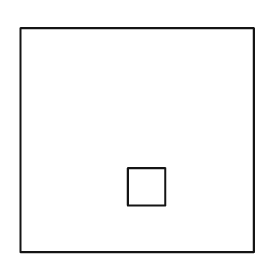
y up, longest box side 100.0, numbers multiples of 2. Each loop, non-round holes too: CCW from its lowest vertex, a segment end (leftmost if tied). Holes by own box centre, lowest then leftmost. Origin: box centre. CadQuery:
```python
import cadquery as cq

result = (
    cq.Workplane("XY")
    .moveTo(-50.0, -48.0)
    .lineTo(50.0, -48.0)
    .lineTo(50.0, 48.0)
    .lineTo(-50.0, 48.0)
    .close()
    .moveTo(-4.0, -28.0)
    .lineTo(12.0, -28.0)
    .lineTo(12.0, -12.0)
    .lineTo(-4.0, -12.0)
    .close()
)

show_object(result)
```